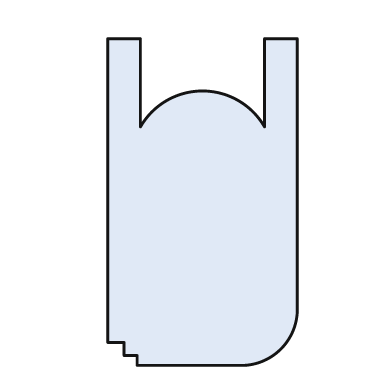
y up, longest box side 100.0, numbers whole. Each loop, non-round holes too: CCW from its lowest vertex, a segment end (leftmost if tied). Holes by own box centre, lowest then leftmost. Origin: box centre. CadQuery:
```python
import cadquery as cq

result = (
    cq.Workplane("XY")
    .moveTo(-20.0, -50.0)
    .lineTo(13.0, -50.0)
    .threePointArc((24.0, -45.0), (29.0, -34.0))
    .lineTo(29.0, 50.0)
    .lineTo(19.0, 50.0)
    .lineTo(19.0, 23.0)
    .threePointArc((0.0, 34.0), (-19.0, 23.0))
    .lineTo(-19.0, 50.0)
    .lineTo(-29.0, 50.0)
    .lineTo(-29.0, -43.0)
    .lineTo(-24.0, -43.0)
    .lineTo(-24.0, -47.0)
    .lineTo(-20.0, -47.0)
    .close()
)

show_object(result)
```